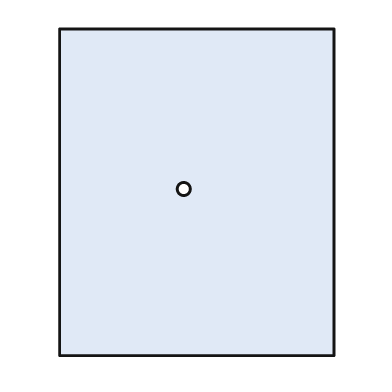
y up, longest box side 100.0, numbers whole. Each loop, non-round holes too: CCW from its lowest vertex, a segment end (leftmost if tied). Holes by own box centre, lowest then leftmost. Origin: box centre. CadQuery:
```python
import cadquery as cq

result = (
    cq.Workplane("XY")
    .moveTo(-42.0, -50.0)
    .lineTo(42.0, -50.0)
    .lineTo(42.0, 50.0)
    .lineTo(-42.0, 50.0)
    .close()
    .moveTo(-4.0, 1.0)
    .circle(2.0)
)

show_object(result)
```